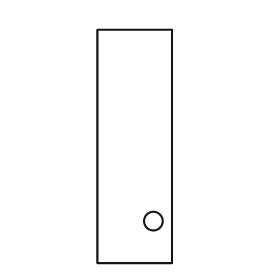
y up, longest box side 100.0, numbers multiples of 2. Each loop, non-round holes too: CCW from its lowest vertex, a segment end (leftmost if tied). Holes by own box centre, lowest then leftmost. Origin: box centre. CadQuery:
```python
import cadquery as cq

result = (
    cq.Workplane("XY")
    .moveTo(-16.0, -50.0)
    .lineTo(16.0, -50.0)
    .lineTo(16.0, 50.0)
    .lineTo(-16.0, 50.0)
    .close()
    .moveTo(8.0, -32.0)
    .circle(4.0)
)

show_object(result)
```